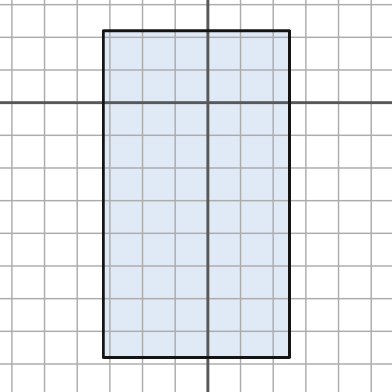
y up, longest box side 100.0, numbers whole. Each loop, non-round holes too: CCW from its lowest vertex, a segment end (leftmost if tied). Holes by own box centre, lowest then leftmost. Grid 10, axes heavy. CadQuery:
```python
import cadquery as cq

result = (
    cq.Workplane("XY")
    .moveTo(-32.0, -78.0)
    .lineTo(25.0, -78.0)
    .lineTo(25.0, 22.0)
    .lineTo(-32.0, 22.0)
    .close()
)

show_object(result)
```